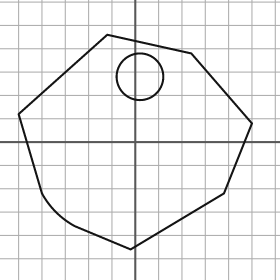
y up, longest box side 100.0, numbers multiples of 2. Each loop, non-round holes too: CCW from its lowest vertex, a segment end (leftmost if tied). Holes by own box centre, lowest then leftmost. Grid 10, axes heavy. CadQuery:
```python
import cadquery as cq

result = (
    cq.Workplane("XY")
    .moveTo(-2.0, -46.0)
    .lineTo(38.0, -22.0)
    .lineTo(50.0, 8.0)
    .lineTo(24.0, 38.0)
    .lineTo(-12.0, 46.0)
    .lineTo(-50.0, 12.0)
    .lineTo(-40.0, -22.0)
    .threePointArc((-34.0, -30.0), (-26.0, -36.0))
    .close()
    .moveTo(2.0, 28.0)
    .circle(10.0)
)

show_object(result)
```